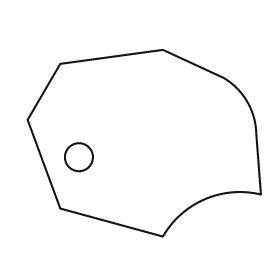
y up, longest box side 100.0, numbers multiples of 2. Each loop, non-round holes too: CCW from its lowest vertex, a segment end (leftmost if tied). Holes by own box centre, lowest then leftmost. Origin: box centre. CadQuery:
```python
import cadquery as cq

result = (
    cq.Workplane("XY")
    .moveTo(8.0, -40.0)
    .threePointArc((26.0, -24.0), (50.0, -22.0))
    .lineTo(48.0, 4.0)
    .threePointArc((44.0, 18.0), (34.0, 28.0))
    .lineTo(8.0, 40.0)
    .lineTo(-36.0, 34.0)
    .lineTo(-50.0, 10.0)
    .lineTo(-36.0, -28.0)
    .close()
    .moveTo(-28.0, -6.0)
    .circle(6.0)
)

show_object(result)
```